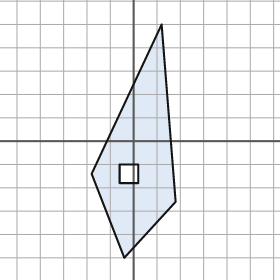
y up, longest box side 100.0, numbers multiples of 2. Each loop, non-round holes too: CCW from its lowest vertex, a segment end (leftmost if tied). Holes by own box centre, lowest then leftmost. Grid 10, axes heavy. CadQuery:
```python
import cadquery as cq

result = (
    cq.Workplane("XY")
    .moveTo(-4.0, -50.0)
    .lineTo(18.0, -26.0)
    .lineTo(12.0, 50.0)
    .lineTo(-18.0, -14.0)
    .close()
    .moveTo(-6.0, -18.0)
    .lineTo(2.0, -18.0)
    .lineTo(2.0, -10.0)
    .lineTo(-6.0, -10.0)
    .close()
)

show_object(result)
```